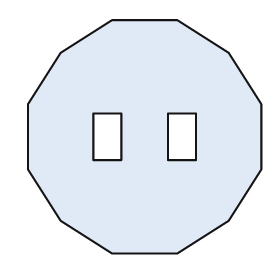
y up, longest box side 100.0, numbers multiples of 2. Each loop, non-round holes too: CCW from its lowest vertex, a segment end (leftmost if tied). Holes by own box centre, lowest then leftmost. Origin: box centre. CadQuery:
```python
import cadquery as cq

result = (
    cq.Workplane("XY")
    .moveTo(-14.0, -50.0)
    .lineTo(14.0, -50.0)
    .lineTo(36.0, -36.0)
    .lineTo(50.0, -14.0)
    .lineTo(50.0, 14.0)
    .lineTo(36.0, 36.0)
    .lineTo(14.0, 50.0)
    .lineTo(-14.0, 50.0)
    .lineTo(-36.0, 36.0)
    .lineTo(-50.0, 14.0)
    .lineTo(-50.0, -14.0)
    .lineTo(-36.0, -36.0)
    .close()
    .moveTo(-22.0, -10.0)
    .lineTo(-10.0, -10.0)
    .lineTo(-10.0, 10.0)
    .lineTo(-22.0, 10.0)
    .close()
    .moveTo(10.0, -10.0)
    .lineTo(22.0, -10.0)
    .lineTo(22.0, 10.0)
    .lineTo(10.0, 10.0)
    .close()
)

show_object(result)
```